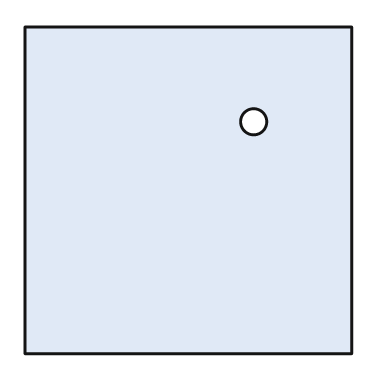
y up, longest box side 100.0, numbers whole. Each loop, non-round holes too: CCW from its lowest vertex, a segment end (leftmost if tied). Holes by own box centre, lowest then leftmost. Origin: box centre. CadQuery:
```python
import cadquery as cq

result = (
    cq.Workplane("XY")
    .moveTo(-50.0, -50.0)
    .lineTo(50.0, -50.0)
    .lineTo(50.0, 50.0)
    .lineTo(-50.0, 50.0)
    .close()
    .moveTo(20.0, 21.0)
    .circle(4.0)
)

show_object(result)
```